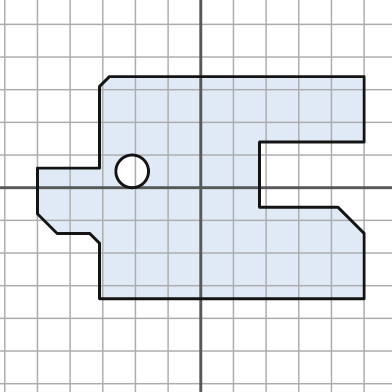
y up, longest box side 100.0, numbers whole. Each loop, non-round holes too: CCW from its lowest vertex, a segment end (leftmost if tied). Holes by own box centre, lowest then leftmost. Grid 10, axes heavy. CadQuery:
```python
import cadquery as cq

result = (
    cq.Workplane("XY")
    .moveTo(-31.0, -34.0)
    .lineTo(50.0, -34.0)
    .lineTo(50.0, -14.0)
    .lineTo(42.0, -6.0)
    .lineTo(18.0, -6.0)
    .lineTo(18.0, 14.0)
    .lineTo(50.0, 14.0)
    .lineTo(50.0, 34.0)
    .lineTo(-28.0, 34.0)
    .lineTo(-31.0, 31.0)
    .lineTo(-31.0, 6.0)
    .lineTo(-50.0, 6.0)
    .lineTo(-50.0, -8.0)
    .lineTo(-44.0, -14.0)
    .lineTo(-34.0, -14.0)
    .lineTo(-31.0, -17.0)
    .close()
    .moveTo(-21.0, 5.0)
    .circle(5.0)
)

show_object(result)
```